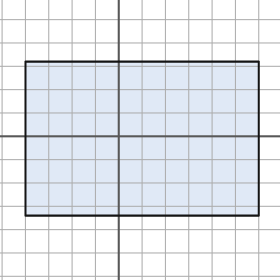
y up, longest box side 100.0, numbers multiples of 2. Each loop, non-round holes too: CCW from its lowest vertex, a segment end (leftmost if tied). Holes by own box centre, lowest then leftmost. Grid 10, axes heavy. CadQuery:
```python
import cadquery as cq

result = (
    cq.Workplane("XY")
    .moveTo(-40.0, -34.0)
    .lineTo(60.0, -34.0)
    .lineTo(60.0, 32.0)
    .lineTo(-40.0, 32.0)
    .close()
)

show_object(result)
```